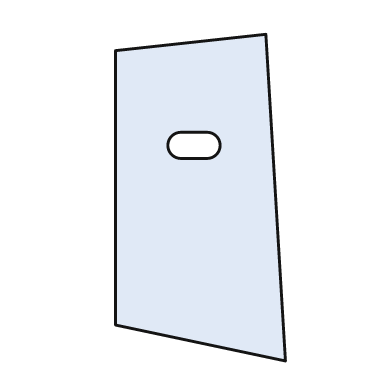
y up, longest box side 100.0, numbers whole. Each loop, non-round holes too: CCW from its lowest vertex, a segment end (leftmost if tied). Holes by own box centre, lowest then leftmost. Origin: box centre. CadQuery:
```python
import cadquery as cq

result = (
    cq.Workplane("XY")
    .moveTo(26.0, -50.0)
    .lineTo(20.0, 50.0)
    .lineTo(-26.0, 45.0)
    .lineTo(-26.0, -39.0)
    .close()
    .moveTo(-6.0, 12.0)
    .lineTo(2.0, 12.0)
    .threePointArc((6.0, 16.0), (2.0, 20.0))
    .lineTo(-6.0, 20.0)
    .threePointArc((-10.0, 16.0), (-6.0, 12.0))
    .close()
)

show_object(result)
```